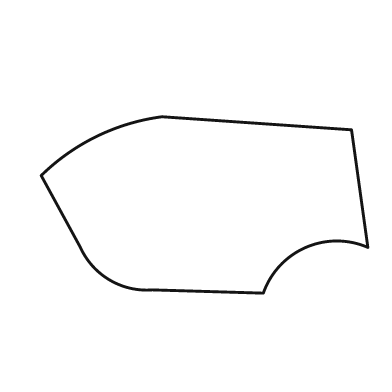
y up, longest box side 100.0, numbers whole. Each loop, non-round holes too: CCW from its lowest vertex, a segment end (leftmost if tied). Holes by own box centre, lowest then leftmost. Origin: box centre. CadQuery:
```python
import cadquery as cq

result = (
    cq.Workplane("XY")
    .moveTo(18.0, -27.0)
    .threePointArc((31.0, -13.0), (50.0, -13.0))
    .lineTo(45.0, 23.0)
    .lineTo(-13.0, 27.0)
    .threePointArc((-33.0, 21.0), (-50.0, 9.0))
    .lineTo(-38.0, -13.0)
    .threePointArc((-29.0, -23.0), (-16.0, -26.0))
    .close()
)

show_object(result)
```